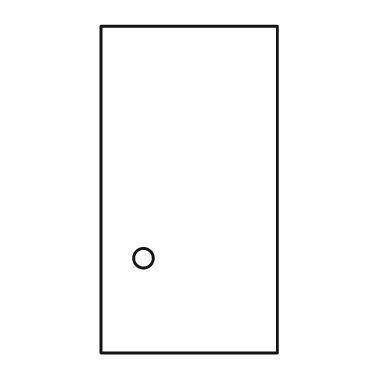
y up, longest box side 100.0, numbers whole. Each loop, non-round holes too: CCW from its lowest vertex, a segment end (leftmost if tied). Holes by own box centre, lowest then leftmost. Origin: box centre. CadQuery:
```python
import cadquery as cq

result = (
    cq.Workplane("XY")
    .moveTo(-27.0, -50.0)
    .lineTo(27.0, -50.0)
    .lineTo(27.0, 50.0)
    .lineTo(-27.0, 50.0)
    .close()
    .moveTo(-14.0, -21.0)
    .circle(3.0)
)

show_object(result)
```